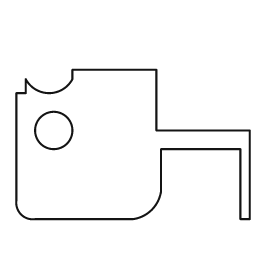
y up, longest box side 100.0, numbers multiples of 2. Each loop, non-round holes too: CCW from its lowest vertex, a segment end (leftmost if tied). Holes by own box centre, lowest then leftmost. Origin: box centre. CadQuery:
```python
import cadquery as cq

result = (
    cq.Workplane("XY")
    .moveTo(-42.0, -32.0)
    .lineTo(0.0, -32.0)
    .threePointArc((8.0, -28.0), (12.0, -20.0))
    .lineTo(12.0, -2.0)
    .lineTo(46.0, -2.0)
    .lineTo(46.0, -32.0)
    .lineTo(50.0, -32.0)
    .lineTo(50.0, 6.0)
    .lineTo(10.0, 6.0)
    .lineTo(10.0, 32.0)
    .lineTo(-26.0, 32.0)
    .lineTo(-26.0, 28.0)
    .threePointArc((-36.0, 22.0), (-46.0, 28.0))
    .lineTo(-46.0, 22.0)
    .lineTo(-50.0, 22.0)
    .lineTo(-50.0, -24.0)
    .threePointArc((-48.0, -30.0), (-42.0, -32.0))
    .close()
    .moveTo(-34.0, 6.0)
    .circle(8.0)
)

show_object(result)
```